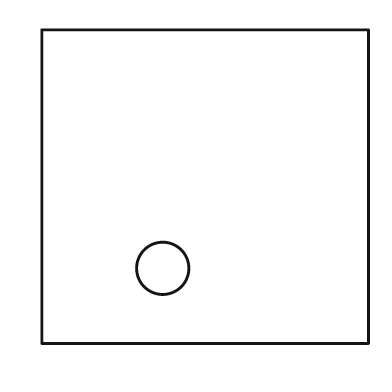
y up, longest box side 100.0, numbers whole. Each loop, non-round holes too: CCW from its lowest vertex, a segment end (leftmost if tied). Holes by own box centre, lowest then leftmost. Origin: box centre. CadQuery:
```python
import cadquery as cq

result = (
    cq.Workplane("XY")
    .moveTo(-50.0, -48.0)
    .lineTo(50.0, -48.0)
    .lineTo(50.0, 48.0)
    .lineTo(-50.0, 48.0)
    .close()
    .moveTo(-13.0, -25.0)
    .circle(8.0)
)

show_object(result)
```